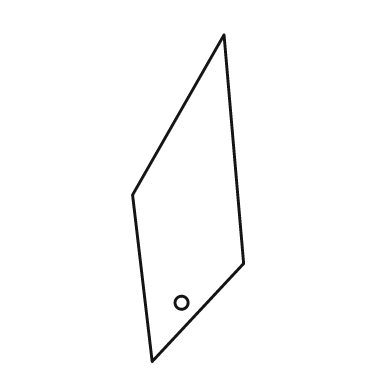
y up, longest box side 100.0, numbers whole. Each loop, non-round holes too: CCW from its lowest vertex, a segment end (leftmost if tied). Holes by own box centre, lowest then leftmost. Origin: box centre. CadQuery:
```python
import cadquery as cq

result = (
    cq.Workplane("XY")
    .moveTo(-11.0, -50.0)
    .lineTo(17.0, -20.0)
    .lineTo(11.0, 50.0)
    .lineTo(-17.0, 1.0)
    .close()
    .moveTo(-2.0, -32.0)
    .circle(2.0)
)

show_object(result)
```